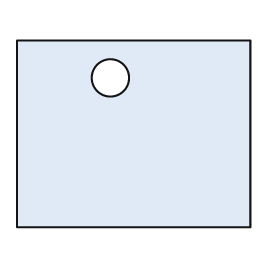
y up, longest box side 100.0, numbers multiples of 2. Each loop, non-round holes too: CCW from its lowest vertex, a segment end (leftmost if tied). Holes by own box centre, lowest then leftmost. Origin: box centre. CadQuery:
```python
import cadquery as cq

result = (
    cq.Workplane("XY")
    .moveTo(-50.0, -40.0)
    .lineTo(50.0, -40.0)
    .lineTo(50.0, 40.0)
    .lineTo(-50.0, 40.0)
    .close()
    .moveTo(-10.0, 24.0)
    .circle(8.0)
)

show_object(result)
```